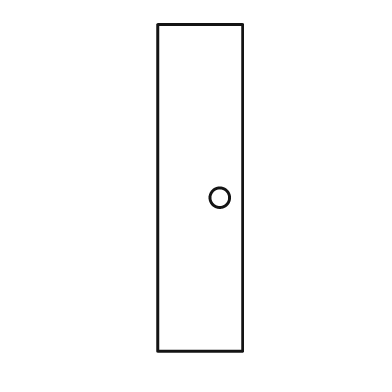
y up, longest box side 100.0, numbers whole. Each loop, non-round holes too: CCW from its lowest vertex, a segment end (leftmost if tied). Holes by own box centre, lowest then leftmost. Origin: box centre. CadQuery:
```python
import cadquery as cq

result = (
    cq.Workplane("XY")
    .moveTo(-13.0, -50.0)
    .lineTo(13.0, -50.0)
    .lineTo(13.0, 50.0)
    .lineTo(-13.0, 50.0)
    .close()
    .moveTo(6.0, -3.0)
    .circle(3.0)
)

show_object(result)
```